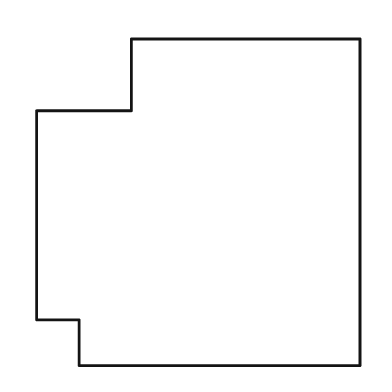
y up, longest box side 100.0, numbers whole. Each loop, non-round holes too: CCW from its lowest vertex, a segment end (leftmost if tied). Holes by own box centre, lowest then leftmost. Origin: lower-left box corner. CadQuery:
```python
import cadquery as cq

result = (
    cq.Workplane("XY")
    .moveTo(13.0, 0.0)
    .lineTo(99.0, 0.0)
    .lineTo(99.0, 100.0)
    .lineTo(29.0, 100.0)
    .lineTo(29.0, 78.0)
    .lineTo(0.0, 78.0)
    .lineTo(0.0, 14.0)
    .lineTo(13.0, 14.0)
    .close()
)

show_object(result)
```